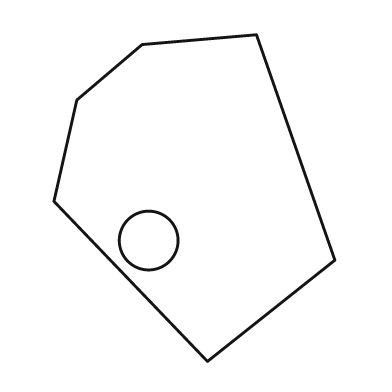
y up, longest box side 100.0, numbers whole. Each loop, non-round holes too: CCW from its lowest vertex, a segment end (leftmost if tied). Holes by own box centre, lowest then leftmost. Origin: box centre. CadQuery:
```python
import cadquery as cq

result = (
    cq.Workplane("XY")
    .moveTo(4.0, -50.0)
    .lineTo(43.0, -19.0)
    .lineTo(19.0, 50.0)
    .lineTo(-16.0, 47.0)
    .lineTo(-36.0, 30.0)
    .lineTo(-43.0, -1.0)
    .close()
    .moveTo(-14.0, -13.0)
    .circle(9.0)
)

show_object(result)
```